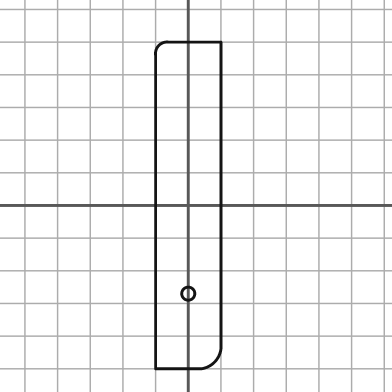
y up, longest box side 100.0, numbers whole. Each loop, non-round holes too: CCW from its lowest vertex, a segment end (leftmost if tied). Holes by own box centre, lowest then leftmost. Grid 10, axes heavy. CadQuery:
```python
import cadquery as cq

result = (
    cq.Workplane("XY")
    .moveTo(-10.0, -50.0)
    .lineTo(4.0, -50.0)
    .threePointArc((8.0, -48.0), (10.0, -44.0))
    .lineTo(10.0, 50.0)
    .lineTo(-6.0, 50.0)
    .threePointArc((-9.0, 49.0), (-10.0, 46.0))
    .close()
    .moveTo(0.0, -27.0)
    .circle(2.0)
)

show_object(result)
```